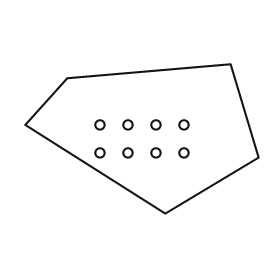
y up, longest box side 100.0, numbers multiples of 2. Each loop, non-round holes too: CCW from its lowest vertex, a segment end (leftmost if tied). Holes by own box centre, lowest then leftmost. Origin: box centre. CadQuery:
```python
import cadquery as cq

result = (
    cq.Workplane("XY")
    .moveTo(10.0, -32.0)
    .lineTo(50.0, -8.0)
    .lineTo(38.0, 32.0)
    .lineTo(-32.0, 26.0)
    .lineTo(-50.0, 6.0)
    .close()
    .moveTo(-18.0, -6.0)
    .circle(2.0)
    .moveTo(-6.0, -6.0)
    .circle(2.0)
    .moveTo(6.0, -6.0)
    .circle(2.0)
    .moveTo(18.0, -6.0)
    .circle(2.0)
    .moveTo(-18.0, 6.0)
    .circle(2.0)
    .moveTo(-6.0, 6.0)
    .circle(2.0)
    .moveTo(6.0, 6.0)
    .circle(2.0)
    .moveTo(18.0, 6.0)
    .circle(2.0)
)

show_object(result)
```